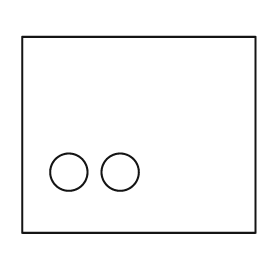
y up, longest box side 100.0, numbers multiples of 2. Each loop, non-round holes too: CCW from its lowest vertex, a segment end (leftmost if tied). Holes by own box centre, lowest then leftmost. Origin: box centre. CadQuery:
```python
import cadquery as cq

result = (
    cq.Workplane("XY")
    .moveTo(-50.0, -42.0)
    .lineTo(50.0, -42.0)
    .lineTo(50.0, 42.0)
    .lineTo(-50.0, 42.0)
    .close()
    .moveTo(-30.0, -16.0)
    .circle(8.0)
    .moveTo(-8.0, -16.0)
    .circle(8.0)
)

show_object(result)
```